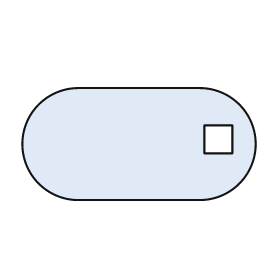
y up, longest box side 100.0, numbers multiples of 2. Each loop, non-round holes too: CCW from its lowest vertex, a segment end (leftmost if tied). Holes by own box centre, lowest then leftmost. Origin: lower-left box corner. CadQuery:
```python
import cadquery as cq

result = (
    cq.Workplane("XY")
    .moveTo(24.0, 0.0)
    .lineTo(76.0, 0.0)
    .threePointArc((100.0, 24.0), (76.0, 48.0))
    .lineTo(24.0, 48.0)
    .threePointArc((0.0, 24.0), (24.0, 0.0))
    .close()
    .moveTo(78.0, 20.0)
    .lineTo(90.0, 20.0)
    .lineTo(90.0, 32.0)
    .lineTo(78.0, 32.0)
    .close()
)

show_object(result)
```